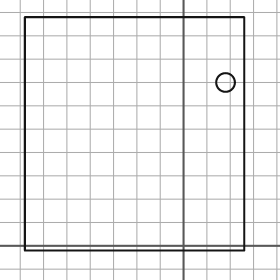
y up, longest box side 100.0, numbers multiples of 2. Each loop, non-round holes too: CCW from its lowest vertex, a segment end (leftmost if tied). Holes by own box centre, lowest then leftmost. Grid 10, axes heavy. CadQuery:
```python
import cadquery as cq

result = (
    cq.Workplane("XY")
    .moveTo(-68.0, -2.0)
    .lineTo(26.0, -2.0)
    .lineTo(26.0, 98.0)
    .lineTo(-68.0, 98.0)
    .close()
    .moveTo(18.0, 70.0)
    .circle(4.0)
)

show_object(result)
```